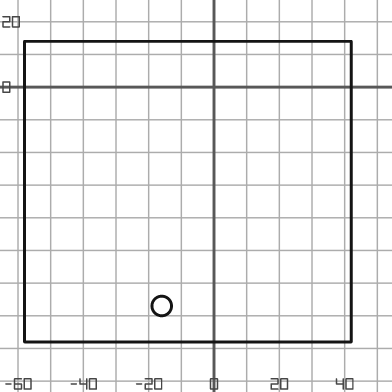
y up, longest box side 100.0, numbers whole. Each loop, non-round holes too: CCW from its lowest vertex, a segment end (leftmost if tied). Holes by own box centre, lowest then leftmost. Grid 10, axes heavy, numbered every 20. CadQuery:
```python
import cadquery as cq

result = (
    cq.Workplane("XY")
    .moveTo(-58.0, -78.0)
    .lineTo(42.0, -78.0)
    .lineTo(42.0, 14.0)
    .lineTo(-58.0, 14.0)
    .close()
    .moveTo(-16.0, -67.0)
    .circle(3.0)
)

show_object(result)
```